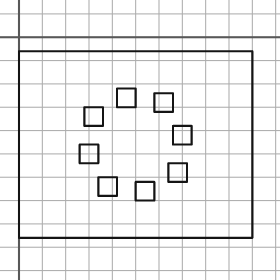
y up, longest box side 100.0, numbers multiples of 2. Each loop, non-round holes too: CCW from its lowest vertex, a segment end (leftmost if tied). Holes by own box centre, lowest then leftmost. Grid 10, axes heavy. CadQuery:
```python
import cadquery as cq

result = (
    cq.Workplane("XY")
    .moveTo(0.0, -86.0)
    .lineTo(100.0, -86.0)
    .lineTo(100.0, -6.0)
    .lineTo(0.0, -6.0)
    .close()
    .moveTo(50.0, -70.0)
    .lineTo(58.0, -70.0)
    .lineTo(58.0, -62.0)
    .lineTo(50.0, -62.0)
    .close()
    .moveTo(34.0, -68.0)
    .lineTo(42.0, -68.0)
    .lineTo(42.0, -60.0)
    .lineTo(34.0, -60.0)
    .close()
    .moveTo(64.0, -62.0)
    .lineTo(72.0, -62.0)
    .lineTo(72.0, -54.0)
    .lineTo(64.0, -54.0)
    .close()
    .moveTo(26.0, -54.0)
    .lineTo(34.0, -54.0)
    .lineTo(34.0, -46.0)
    .lineTo(26.0, -46.0)
    .close()
    .moveTo(66.0, -46.0)
    .lineTo(74.0, -46.0)
    .lineTo(74.0, -38.0)
    .lineTo(66.0, -38.0)
    .close()
    .moveTo(28.0, -38.0)
    .lineTo(36.0, -38.0)
    .lineTo(36.0, -30.0)
    .lineTo(28.0, -30.0)
    .close()
    .moveTo(58.0, -32.0)
    .lineTo(66.0, -32.0)
    .lineTo(66.0, -24.0)
    .lineTo(58.0, -24.0)
    .close()
    .moveTo(42.0, -30.0)
    .lineTo(50.0, -30.0)
    .lineTo(50.0, -22.0)
    .lineTo(42.0, -22.0)
    .close()
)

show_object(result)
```